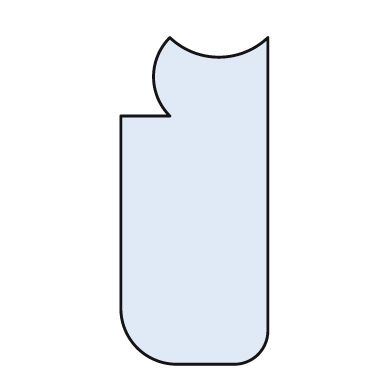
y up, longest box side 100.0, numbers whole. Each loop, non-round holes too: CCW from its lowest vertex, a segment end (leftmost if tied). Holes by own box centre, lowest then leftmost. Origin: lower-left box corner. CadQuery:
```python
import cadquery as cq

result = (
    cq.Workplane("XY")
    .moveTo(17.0, 0.0)
    .lineTo(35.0, 0.0)
    .threePointArc((42.0, 3.0), (45.0, 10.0))
    .lineTo(45.0, 100.0)
    .threePointArc((30.0, 94.0), (15.0, 100.0))
    .threePointArc((10.0, 88.0), (15.0, 76.0))
    .lineTo(0.0, 76.0)
    .lineTo(0.0, 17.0)
    .threePointArc((5.0, 5.0), (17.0, 0.0))
    .close()
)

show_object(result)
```